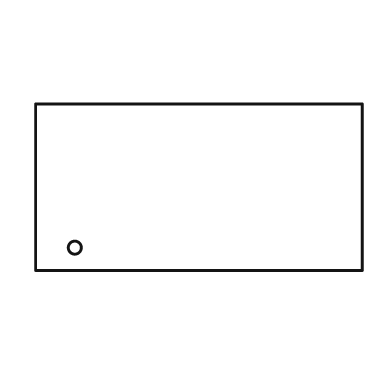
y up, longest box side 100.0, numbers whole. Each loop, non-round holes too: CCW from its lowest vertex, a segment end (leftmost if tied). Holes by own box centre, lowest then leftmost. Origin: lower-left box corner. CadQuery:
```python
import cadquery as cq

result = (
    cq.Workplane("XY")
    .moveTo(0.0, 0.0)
    .lineTo(100.0, 0.0)
    .lineTo(100.0, 51.0)
    .lineTo(0.0, 51.0)
    .close()
    .moveTo(12.0, 7.0)
    .circle(2.0)
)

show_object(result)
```